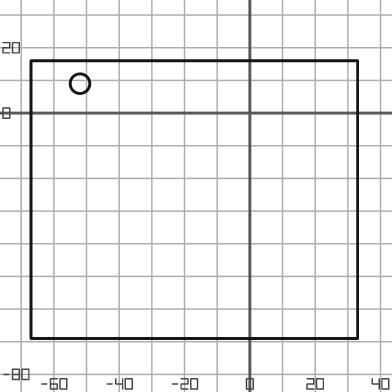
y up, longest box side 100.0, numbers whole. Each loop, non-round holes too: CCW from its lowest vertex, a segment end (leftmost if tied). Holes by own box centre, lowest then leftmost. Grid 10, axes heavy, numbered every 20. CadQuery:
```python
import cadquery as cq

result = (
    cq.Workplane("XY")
    .moveTo(-67.0, -69.0)
    .lineTo(33.0, -69.0)
    .lineTo(33.0, 16.0)
    .lineTo(-67.0, 16.0)
    .close()
    .moveTo(-52.0, 9.0)
    .circle(3.0)
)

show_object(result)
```